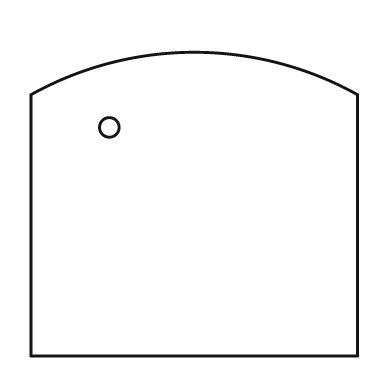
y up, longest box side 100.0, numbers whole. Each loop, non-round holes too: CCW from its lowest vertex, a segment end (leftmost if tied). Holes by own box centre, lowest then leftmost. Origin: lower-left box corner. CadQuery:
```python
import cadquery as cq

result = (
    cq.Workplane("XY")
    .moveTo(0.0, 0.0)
    .lineTo(100.0, 0.0)
    .lineTo(100.0, 80.0)
    .threePointArc((50.0, 93.0), (0.0, 80.0))
    .close()
    .moveTo(24.0, 70.0)
    .circle(3.0)
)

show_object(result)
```